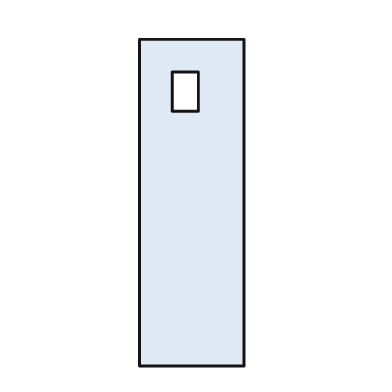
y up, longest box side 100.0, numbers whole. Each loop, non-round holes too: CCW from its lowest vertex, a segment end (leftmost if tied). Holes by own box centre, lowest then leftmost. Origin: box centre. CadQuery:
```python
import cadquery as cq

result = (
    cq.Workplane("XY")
    .moveTo(-16.0, -50.0)
    .lineTo(16.0, -50.0)
    .lineTo(16.0, 50.0)
    .lineTo(-16.0, 50.0)
    .close()
    .moveTo(-6.0, 28.0)
    .lineTo(2.0, 28.0)
    .lineTo(2.0, 40.0)
    .lineTo(-6.0, 40.0)
    .close()
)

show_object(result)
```